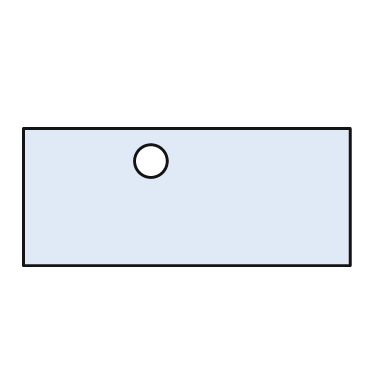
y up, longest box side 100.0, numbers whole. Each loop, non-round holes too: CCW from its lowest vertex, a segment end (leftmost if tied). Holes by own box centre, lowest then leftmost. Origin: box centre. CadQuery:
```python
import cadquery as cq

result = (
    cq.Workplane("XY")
    .moveTo(-50.0, -21.0)
    .lineTo(50.0, -21.0)
    .lineTo(50.0, 21.0)
    .lineTo(-50.0, 21.0)
    .close()
    .moveTo(-11.0, 11.0)
    .circle(5.0)
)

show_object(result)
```